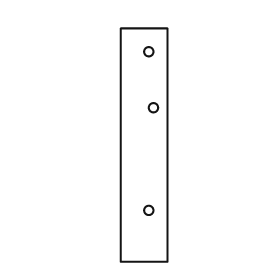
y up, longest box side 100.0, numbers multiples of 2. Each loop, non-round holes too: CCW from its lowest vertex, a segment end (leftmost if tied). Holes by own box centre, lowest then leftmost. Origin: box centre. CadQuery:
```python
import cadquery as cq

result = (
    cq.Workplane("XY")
    .moveTo(-10.0, -50.0)
    .lineTo(10.0, -50.0)
    .lineTo(10.0, 50.0)
    .lineTo(-10.0, 50.0)
    .close()
    .moveTo(2.0, -28.0)
    .circle(2.0)
    .moveTo(4.0, 16.0)
    .circle(2.0)
    .moveTo(2.0, 40.0)
    .circle(2.0)
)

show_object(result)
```